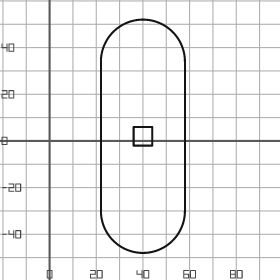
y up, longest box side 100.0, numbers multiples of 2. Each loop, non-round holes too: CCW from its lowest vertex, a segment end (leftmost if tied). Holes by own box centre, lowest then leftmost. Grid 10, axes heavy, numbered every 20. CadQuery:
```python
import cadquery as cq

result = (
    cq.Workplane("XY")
    .moveTo(22.0, -30.0)
    .threePointArc((40.0, -48.0), (58.0, -30.0))
    .lineTo(58.0, 34.0)
    .threePointArc((40.0, 52.0), (22.0, 34.0))
    .close()
    .moveTo(36.0, -2.0)
    .lineTo(44.0, -2.0)
    .lineTo(44.0, 6.0)
    .lineTo(36.0, 6.0)
    .close()
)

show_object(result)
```